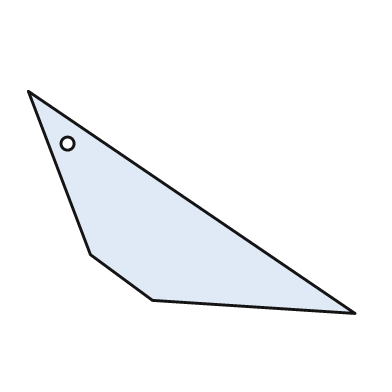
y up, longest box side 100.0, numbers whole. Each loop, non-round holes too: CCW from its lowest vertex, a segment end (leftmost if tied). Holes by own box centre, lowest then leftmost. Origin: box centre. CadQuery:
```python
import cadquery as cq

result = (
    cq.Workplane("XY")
    .moveTo(50.0, -34.0)
    .lineTo(-50.0, 34.0)
    .lineTo(-31.0, -16.0)
    .lineTo(-12.0, -30.0)
    .close()
    .moveTo(-38.0, 18.0)
    .circle(2.0)
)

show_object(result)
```